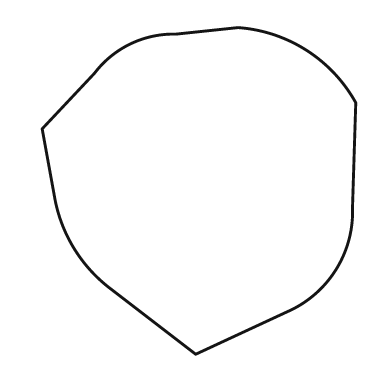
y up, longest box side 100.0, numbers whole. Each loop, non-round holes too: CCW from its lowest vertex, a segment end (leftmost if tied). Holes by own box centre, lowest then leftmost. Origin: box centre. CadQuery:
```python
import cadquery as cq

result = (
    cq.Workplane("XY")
    .moveTo(-1.0, -50.0)
    .lineTo(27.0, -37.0)
    .threePointArc((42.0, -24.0), (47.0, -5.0))
    .lineTo(48.0, 27.0)
    .threePointArc((33.0, 43.0), (12.0, 50.0))
    .lineTo(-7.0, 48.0)
    .threePointArc((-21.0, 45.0), (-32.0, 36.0))
    .lineTo(-48.0, 19.0)
    .lineTo(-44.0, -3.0)
    .threePointArc((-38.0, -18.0), (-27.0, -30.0))
    .close()
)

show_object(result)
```